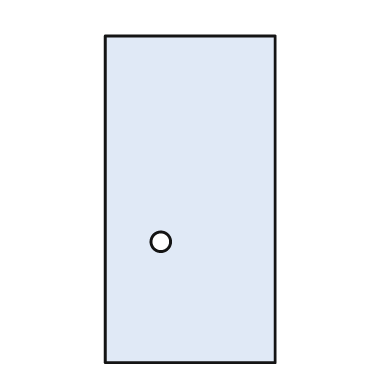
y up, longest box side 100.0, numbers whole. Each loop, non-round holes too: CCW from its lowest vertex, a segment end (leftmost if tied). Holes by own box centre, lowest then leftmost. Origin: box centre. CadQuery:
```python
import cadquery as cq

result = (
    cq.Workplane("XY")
    .moveTo(-26.0, -50.0)
    .lineTo(26.0, -50.0)
    .lineTo(26.0, 50.0)
    .lineTo(-26.0, 50.0)
    .close()
    .moveTo(-9.0, -13.0)
    .circle(3.0)
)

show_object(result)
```